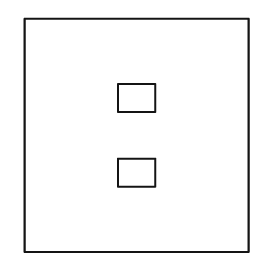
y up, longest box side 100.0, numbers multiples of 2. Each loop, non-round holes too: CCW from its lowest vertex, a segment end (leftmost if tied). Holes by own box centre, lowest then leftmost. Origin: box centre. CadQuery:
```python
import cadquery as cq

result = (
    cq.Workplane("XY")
    .moveTo(-48.0, -50.0)
    .lineTo(48.0, -50.0)
    .lineTo(48.0, 50.0)
    .lineTo(-48.0, 50.0)
    .close()
    .moveTo(-8.0, -22.0)
    .lineTo(8.0, -22.0)
    .lineTo(8.0, -10.0)
    .lineTo(-8.0, -10.0)
    .close()
    .moveTo(-8.0, 10.0)
    .lineTo(8.0, 10.0)
    .lineTo(8.0, 22.0)
    .lineTo(-8.0, 22.0)
    .close()
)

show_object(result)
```